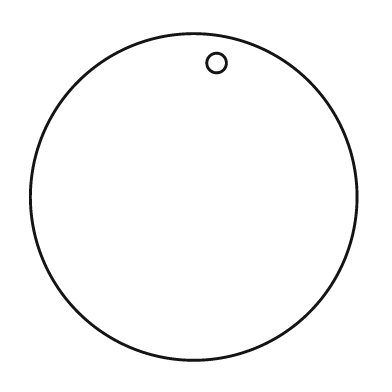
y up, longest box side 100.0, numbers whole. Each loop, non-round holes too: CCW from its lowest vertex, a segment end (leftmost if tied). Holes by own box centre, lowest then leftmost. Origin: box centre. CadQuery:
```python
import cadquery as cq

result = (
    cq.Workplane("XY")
    .moveTo(0.0, 0.0)
    .circle(50.0)
    .moveTo(7.0, 41.0)
    .circle(3.0)
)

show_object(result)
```